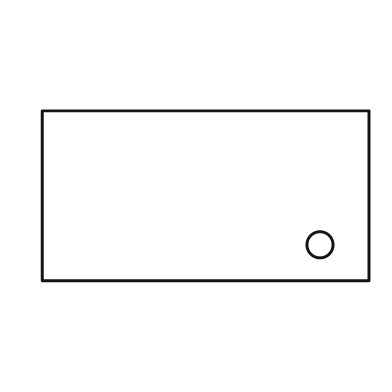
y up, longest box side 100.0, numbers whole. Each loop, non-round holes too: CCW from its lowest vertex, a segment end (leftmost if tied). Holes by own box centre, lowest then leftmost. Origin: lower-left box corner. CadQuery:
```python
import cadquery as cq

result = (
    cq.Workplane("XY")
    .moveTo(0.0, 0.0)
    .lineTo(100.0, 0.0)
    .lineTo(100.0, 52.0)
    .lineTo(0.0, 52.0)
    .close()
    .moveTo(85.0, 11.0)
    .circle(4.0)
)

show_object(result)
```